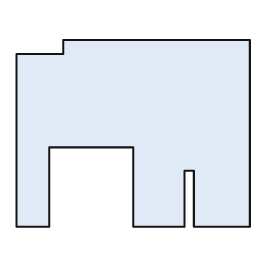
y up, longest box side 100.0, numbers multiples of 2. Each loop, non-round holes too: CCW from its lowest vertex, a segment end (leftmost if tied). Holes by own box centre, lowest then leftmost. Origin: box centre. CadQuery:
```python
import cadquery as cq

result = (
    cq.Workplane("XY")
    .moveTo(-50.0, -40.0)
    .lineTo(-36.0, -40.0)
    .lineTo(-36.0, -6.0)
    .lineTo(0.0, -6.0)
    .lineTo(0.0, -40.0)
    .lineTo(22.0, -40.0)
    .lineTo(22.0, -16.0)
    .lineTo(26.0, -16.0)
    .lineTo(26.0, -40.0)
    .lineTo(50.0, -40.0)
    .lineTo(50.0, 40.0)
    .lineTo(-30.0, 40.0)
    .lineTo(-30.0, 34.0)
    .lineTo(-50.0, 34.0)
    .close()
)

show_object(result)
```